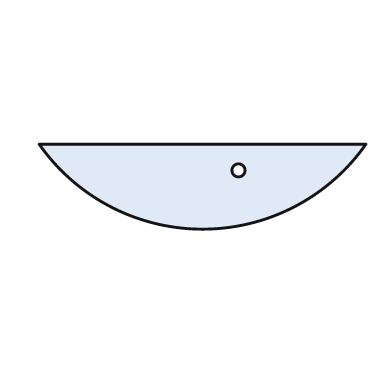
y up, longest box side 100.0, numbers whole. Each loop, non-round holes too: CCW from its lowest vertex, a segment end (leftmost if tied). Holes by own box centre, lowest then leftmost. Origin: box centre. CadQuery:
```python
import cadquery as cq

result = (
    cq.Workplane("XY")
    .moveTo(-50.0, 13.0)
    .threePointArc((0.0, -13.0), (50.0, 13.0))
    .close()
    .moveTo(11.0, 5.0)
    .circle(2.0)
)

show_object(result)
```